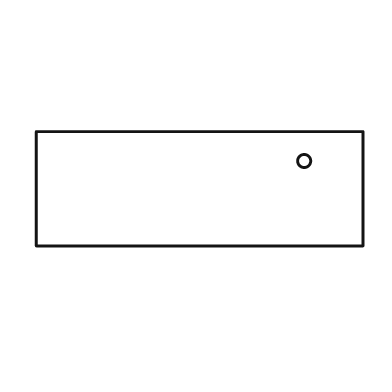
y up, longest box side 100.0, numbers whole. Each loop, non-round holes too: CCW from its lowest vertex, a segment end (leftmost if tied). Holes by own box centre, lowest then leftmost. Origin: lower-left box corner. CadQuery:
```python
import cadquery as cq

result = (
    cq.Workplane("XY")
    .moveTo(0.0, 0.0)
    .lineTo(100.0, 0.0)
    .lineTo(100.0, 35.0)
    .lineTo(0.0, 35.0)
    .close()
    .moveTo(82.0, 26.0)
    .circle(2.0)
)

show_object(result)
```